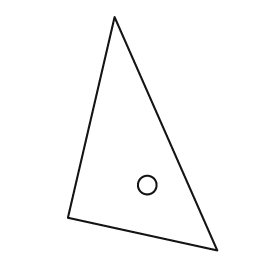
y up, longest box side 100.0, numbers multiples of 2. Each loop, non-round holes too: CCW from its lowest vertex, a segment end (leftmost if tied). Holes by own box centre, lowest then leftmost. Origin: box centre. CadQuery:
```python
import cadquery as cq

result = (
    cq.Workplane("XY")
    .moveTo(32.0, -50.0)
    .lineTo(-12.0, 50.0)
    .lineTo(-32.0, -36.0)
    .close()
    .moveTo(2.0, -22.0)
    .circle(4.0)
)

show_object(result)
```